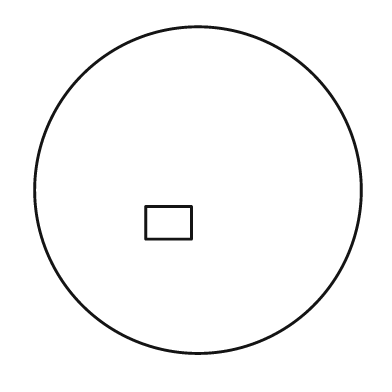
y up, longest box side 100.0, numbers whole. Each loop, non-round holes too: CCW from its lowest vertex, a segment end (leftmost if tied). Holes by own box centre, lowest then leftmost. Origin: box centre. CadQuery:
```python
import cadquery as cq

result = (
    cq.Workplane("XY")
    .moveTo(0.0, 0.0)
    .circle(50.0)
    .moveTo(-16.0, -15.0)
    .lineTo(-2.0, -15.0)
    .lineTo(-2.0, -5.0)
    .lineTo(-16.0, -5.0)
    .close()
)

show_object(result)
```